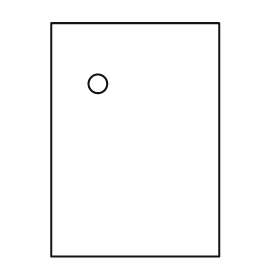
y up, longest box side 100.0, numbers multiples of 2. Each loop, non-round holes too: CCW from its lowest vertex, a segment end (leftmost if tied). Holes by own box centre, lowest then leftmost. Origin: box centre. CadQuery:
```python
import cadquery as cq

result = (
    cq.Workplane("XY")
    .moveTo(-36.0, -50.0)
    .lineTo(36.0, -50.0)
    .lineTo(36.0, 50.0)
    .lineTo(-36.0, 50.0)
    .close()
    .moveTo(-16.0, 24.0)
    .circle(4.0)
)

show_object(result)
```